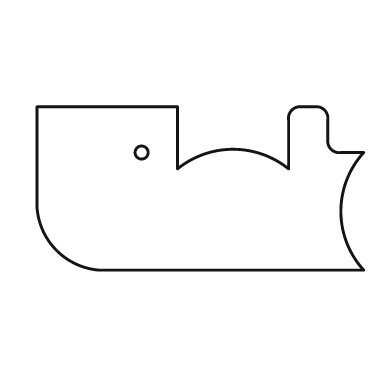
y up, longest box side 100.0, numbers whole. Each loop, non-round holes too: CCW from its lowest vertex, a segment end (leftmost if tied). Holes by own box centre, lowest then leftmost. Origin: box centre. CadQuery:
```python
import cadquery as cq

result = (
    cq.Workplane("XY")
    .moveTo(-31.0, -25.0)
    .lineTo(50.0, -25.0)
    .threePointArc((43.0, -7.0), (50.0, 11.0))
    .lineTo(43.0, 11.0)
    .threePointArc((40.0, 12.0), (39.0, 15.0))
    .lineTo(39.0, 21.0)
    .threePointArc((38.0, 24.0), (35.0, 25.0))
    .lineTo(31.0, 25.0)
    .threePointArc((28.0, 24.0), (27.0, 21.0))
    .lineTo(27.0, 6.0)
    .threePointArc((10.0, 12.0), (-7.0, 6.0))
    .lineTo(-7.0, 25.0)
    .lineTo(-50.0, 25.0)
    .lineTo(-50.0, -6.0)
    .threePointArc((-44.0, -19.0), (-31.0, -25.0))
    .close()
    .moveTo(-18.0, 11.0)
    .circle(2.0)
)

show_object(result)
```